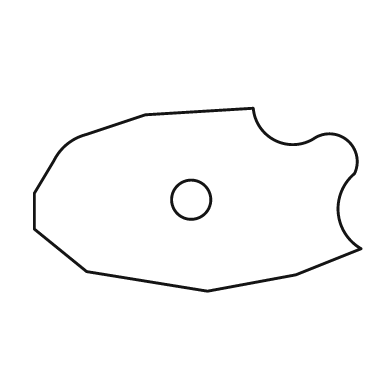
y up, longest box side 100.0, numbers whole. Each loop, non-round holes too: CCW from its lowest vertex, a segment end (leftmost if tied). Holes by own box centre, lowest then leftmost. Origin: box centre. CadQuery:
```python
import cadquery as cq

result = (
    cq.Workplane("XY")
    .moveTo(3.0, -28.0)
    .lineTo(30.0, -23.0)
    .lineTo(50.0, -15.0)
    .threePointArc((43.0, -4.0), (48.0, 8.0))
    .threePointArc((46.0, 18.0), (36.0, 19.0))
    .threePointArc((24.0, 18.0), (17.0, 28.0))
    .lineTo(-16.0, 26.0)
    .lineTo(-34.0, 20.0)
    .threePointArc((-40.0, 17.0), (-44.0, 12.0))
    .lineTo(-50.0, 2.0)
    .lineTo(-50.0, -9.0)
    .lineTo(-34.0, -22.0)
    .close()
    .moveTo(-2.0, 0.0)
    .circle(6.0)
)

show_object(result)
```